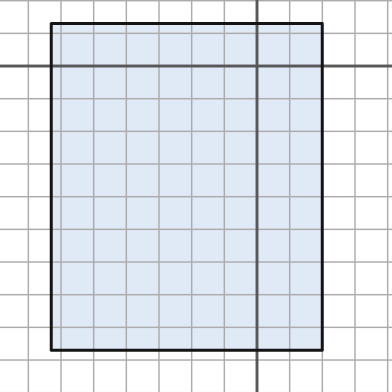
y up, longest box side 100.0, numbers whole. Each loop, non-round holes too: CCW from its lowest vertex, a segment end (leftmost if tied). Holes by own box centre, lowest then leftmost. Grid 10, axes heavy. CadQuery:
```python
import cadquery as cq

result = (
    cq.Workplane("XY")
    .moveTo(-63.0, -87.0)
    .lineTo(20.0, -87.0)
    .lineTo(20.0, 13.0)
    .lineTo(-63.0, 13.0)
    .close()
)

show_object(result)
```